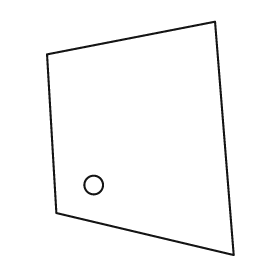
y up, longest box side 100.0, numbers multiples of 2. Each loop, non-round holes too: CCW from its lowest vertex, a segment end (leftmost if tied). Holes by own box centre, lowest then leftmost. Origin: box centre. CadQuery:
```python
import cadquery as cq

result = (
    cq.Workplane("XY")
    .moveTo(40.0, -50.0)
    .lineTo(32.0, 50.0)
    .lineTo(-40.0, 36.0)
    .lineTo(-36.0, -32.0)
    .close()
    .moveTo(-20.0, -20.0)
    .circle(4.0)
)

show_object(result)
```